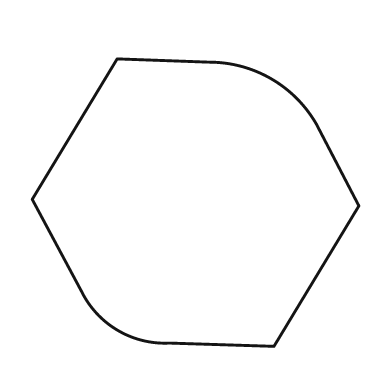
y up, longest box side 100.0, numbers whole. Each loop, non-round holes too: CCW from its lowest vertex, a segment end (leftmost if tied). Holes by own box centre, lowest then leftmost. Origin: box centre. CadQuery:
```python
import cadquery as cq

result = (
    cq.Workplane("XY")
    .moveTo(24.0, -44.0)
    .lineTo(50.0, -1.0)
    .lineTo(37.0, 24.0)
    .threePointArc((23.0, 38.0), (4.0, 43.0))
    .lineTo(-24.0, 44.0)
    .lineTo(-50.0, 1.0)
    .lineTo(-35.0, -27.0)
    .threePointArc((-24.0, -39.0), (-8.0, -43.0))
    .close()
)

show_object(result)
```